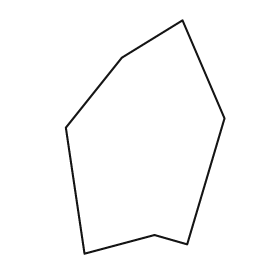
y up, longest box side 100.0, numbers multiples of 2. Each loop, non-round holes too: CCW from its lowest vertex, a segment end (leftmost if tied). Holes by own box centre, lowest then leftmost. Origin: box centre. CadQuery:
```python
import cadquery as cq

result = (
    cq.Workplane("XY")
    .moveTo(-26.0, -50.0)
    .lineTo(4.0, -42.0)
    .lineTo(18.0, -46.0)
    .lineTo(34.0, 8.0)
    .lineTo(16.0, 50.0)
    .lineTo(-10.0, 34.0)
    .lineTo(-34.0, 4.0)
    .close()
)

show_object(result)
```